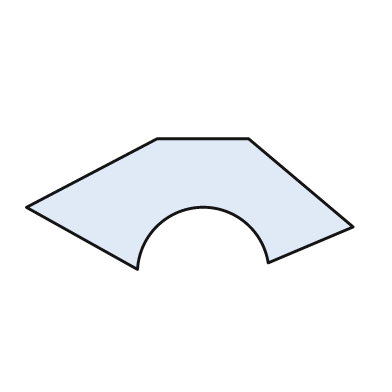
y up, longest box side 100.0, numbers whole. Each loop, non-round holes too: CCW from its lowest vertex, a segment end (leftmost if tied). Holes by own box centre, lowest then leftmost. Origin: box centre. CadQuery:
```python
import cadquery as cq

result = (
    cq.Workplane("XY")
    .moveTo(-16.0, -20.0)
    .threePointArc((3.0, -1.0), (24.0, -18.0))
    .lineTo(50.0, -7.0)
    .lineTo(18.0, 20.0)
    .lineTo(-10.0, 20.0)
    .lineTo(-50.0, -1.0)
    .close()
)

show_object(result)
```